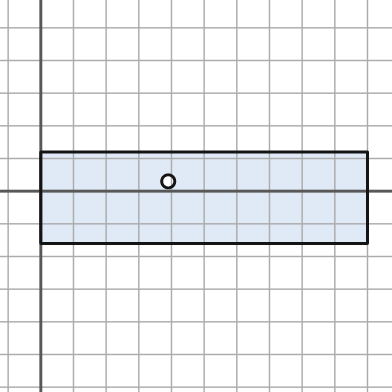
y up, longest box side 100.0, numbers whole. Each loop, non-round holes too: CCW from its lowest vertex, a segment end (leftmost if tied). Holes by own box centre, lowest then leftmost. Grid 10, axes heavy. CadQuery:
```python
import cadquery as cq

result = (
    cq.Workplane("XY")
    .moveTo(0.0, -16.0)
    .lineTo(100.0, -16.0)
    .lineTo(100.0, 12.0)
    .lineTo(0.0, 12.0)
    .close()
    .moveTo(39.0, 3.0)
    .circle(2.0)
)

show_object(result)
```